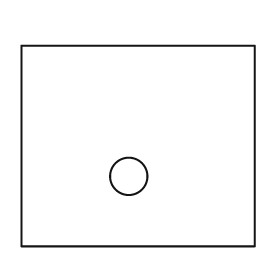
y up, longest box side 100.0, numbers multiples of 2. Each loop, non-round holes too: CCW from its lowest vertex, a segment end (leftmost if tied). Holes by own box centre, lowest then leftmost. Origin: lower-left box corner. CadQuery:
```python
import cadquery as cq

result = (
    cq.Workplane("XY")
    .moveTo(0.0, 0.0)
    .lineTo(100.0, 0.0)
    .lineTo(100.0, 86.0)
    .lineTo(0.0, 86.0)
    .close()
    .moveTo(46.0, 30.0)
    .circle(8.0)
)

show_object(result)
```